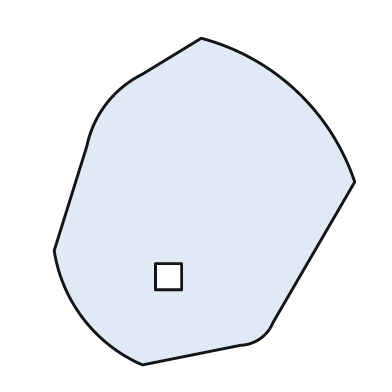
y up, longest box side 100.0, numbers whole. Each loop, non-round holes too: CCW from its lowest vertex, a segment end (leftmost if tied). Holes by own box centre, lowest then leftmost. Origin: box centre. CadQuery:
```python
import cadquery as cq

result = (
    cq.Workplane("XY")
    .moveTo(-19.0, -50.0)
    .lineTo(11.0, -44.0)
    .threePointArc((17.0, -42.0), (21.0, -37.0))
    .lineTo(46.0, 6.0)
    .threePointArc((28.0, 34.0), (-1.0, 50.0))
    .lineTo(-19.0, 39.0)
    .threePointArc((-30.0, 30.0), (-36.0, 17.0))
    .lineTo(-46.0, -15.0)
    .threePointArc((-37.0, -36.0), (-19.0, -50.0))
    .close()
    .moveTo(-15.0, -27.0)
    .lineTo(-7.0, -27.0)
    .lineTo(-7.0, -19.0)
    .lineTo(-15.0, -19.0)
    .close()
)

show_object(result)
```